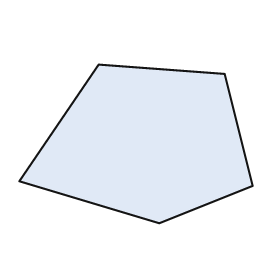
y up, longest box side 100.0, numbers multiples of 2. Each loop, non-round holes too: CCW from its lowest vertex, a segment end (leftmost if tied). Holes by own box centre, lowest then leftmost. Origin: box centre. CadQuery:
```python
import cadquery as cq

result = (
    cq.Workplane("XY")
    .moveTo(10.0, -34.0)
    .lineTo(50.0, -18.0)
    .lineTo(38.0, 30.0)
    .lineTo(-16.0, 34.0)
    .lineTo(-50.0, -16.0)
    .close()
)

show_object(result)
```